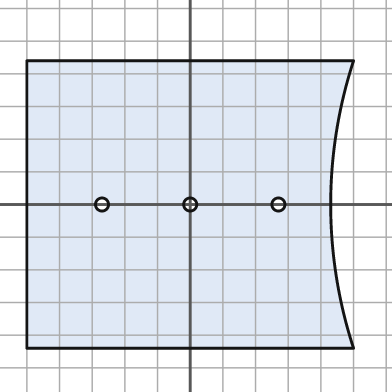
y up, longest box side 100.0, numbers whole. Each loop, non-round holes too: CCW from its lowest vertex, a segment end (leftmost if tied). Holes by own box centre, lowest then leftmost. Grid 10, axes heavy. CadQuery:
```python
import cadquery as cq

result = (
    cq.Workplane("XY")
    .moveTo(-50.0, -44.0)
    .lineTo(50.0, -44.0)
    .threePointArc((43.0, 0.0), (50.0, 44.0))
    .lineTo(-50.0, 44.0)
    .close()
    .moveTo(-27.0, 0.0)
    .circle(2.0)
    .moveTo(0.0, 0.0)
    .circle(2.0)
    .moveTo(27.0, 0.0)
    .circle(2.0)
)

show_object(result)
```